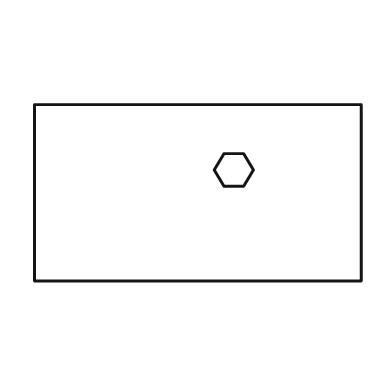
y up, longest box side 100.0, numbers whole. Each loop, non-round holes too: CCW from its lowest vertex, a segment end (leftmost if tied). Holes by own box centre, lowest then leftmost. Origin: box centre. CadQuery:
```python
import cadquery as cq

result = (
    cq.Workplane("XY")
    .moveTo(-50.0, -27.0)
    .lineTo(50.0, -27.0)
    .lineTo(50.0, 27.0)
    .lineTo(-50.0, 27.0)
    .close()
    .moveTo(8.0, 2.0)
    .lineTo(14.0, 2.0)
    .lineTo(17.0, 7.0)
    .lineTo(14.0, 12.0)
    .lineTo(8.0, 12.0)
    .lineTo(5.0, 7.0)
    .close()
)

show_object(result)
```